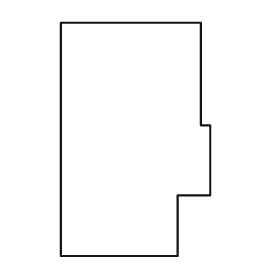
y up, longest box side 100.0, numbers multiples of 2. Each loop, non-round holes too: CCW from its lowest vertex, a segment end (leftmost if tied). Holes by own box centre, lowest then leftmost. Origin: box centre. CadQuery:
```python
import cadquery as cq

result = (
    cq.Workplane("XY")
    .moveTo(-32.0, -50.0)
    .lineTo(18.0, -50.0)
    .lineTo(18.0, -24.0)
    .lineTo(32.0, -24.0)
    .lineTo(32.0, 6.0)
    .lineTo(28.0, 6.0)
    .lineTo(28.0, 50.0)
    .lineTo(-32.0, 50.0)
    .close()
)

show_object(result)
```